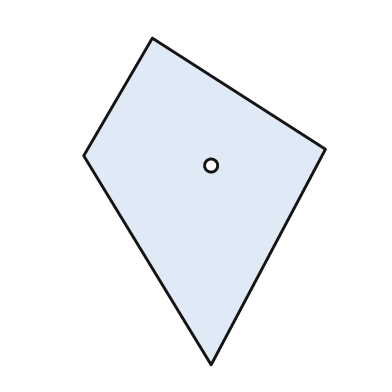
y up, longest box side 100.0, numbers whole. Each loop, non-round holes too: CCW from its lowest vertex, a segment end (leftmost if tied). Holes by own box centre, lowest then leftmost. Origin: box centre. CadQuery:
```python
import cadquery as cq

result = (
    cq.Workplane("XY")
    .moveTo(2.0, -50.0)
    .lineTo(37.0, 16.0)
    .lineTo(-16.0, 50.0)
    .lineTo(-37.0, 14.0)
    .close()
    .moveTo(2.0, 11.0)
    .circle(2.0)
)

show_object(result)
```